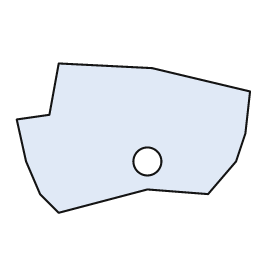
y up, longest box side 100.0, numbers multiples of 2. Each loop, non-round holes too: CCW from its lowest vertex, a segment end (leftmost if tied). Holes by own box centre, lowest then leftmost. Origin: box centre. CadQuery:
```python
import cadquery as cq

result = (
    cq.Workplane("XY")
    .moveTo(-32.0, -32.0)
    .lineTo(6.0, -22.0)
    .lineTo(32.0, -24.0)
    .lineTo(44.0, -10.0)
    .lineTo(48.0, 2.0)
    .lineTo(50.0, 20.0)
    .lineTo(8.0, 30.0)
    .lineTo(-32.0, 32.0)
    .lineTo(-36.0, 10.0)
    .lineTo(-50.0, 8.0)
    .lineTo(-46.0, -10.0)
    .lineTo(-40.0, -24.0)
    .close()
    .moveTo(6.0, -10.0)
    .circle(6.0)
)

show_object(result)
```